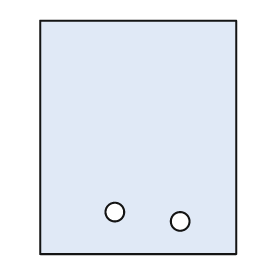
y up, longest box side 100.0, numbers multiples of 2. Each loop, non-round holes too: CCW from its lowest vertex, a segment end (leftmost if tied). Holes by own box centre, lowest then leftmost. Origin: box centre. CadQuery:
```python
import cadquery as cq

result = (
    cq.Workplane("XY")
    .moveTo(-42.0, -50.0)
    .lineTo(42.0, -50.0)
    .lineTo(42.0, 50.0)
    .lineTo(-42.0, 50.0)
    .close()
    .moveTo(18.0, -36.0)
    .circle(4.0)
    .moveTo(-10.0, -32.0)
    .circle(4.0)
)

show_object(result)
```